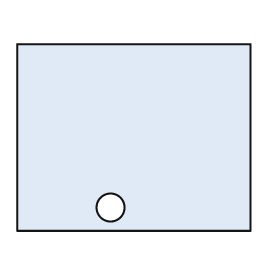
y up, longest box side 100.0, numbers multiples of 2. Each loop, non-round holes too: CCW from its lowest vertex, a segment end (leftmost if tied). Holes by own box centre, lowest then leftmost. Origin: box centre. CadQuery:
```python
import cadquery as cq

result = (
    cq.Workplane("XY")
    .moveTo(-50.0, -40.0)
    .lineTo(50.0, -40.0)
    .lineTo(50.0, 40.0)
    .lineTo(-50.0, 40.0)
    .close()
    .moveTo(-10.0, -30.0)
    .circle(6.0)
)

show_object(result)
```